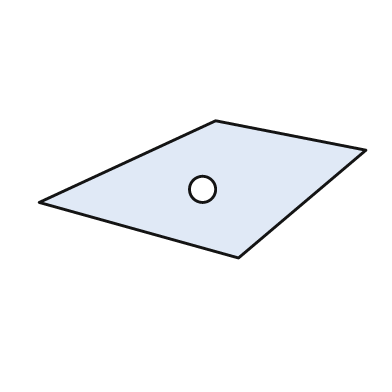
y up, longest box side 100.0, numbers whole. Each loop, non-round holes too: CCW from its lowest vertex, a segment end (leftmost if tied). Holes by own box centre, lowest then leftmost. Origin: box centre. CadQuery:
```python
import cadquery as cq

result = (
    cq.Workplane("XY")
    .moveTo(11.0, -21.0)
    .lineTo(50.0, 12.0)
    .lineTo(4.0, 21.0)
    .lineTo(-50.0, -4.0)
    .close()
    .moveTo(0.0, 0.0)
    .circle(4.0)
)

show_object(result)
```